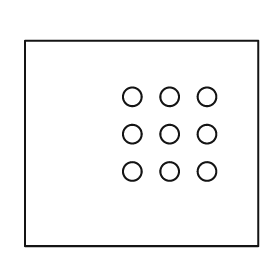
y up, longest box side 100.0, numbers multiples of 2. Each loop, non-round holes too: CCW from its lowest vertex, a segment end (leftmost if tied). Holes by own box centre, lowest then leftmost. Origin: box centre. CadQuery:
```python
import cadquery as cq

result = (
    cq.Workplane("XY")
    .moveTo(-50.0, -44.0)
    .lineTo(50.0, -44.0)
    .lineTo(50.0, 44.0)
    .lineTo(-50.0, 44.0)
    .close()
    .moveTo(-4.0, -12.0)
    .circle(4.0)
    .moveTo(12.0, -12.0)
    .circle(4.0)
    .moveTo(28.0, -12.0)
    .circle(4.0)
    .moveTo(-4.0, 4.0)
    .circle(4.0)
    .moveTo(12.0, 4.0)
    .circle(4.0)
    .moveTo(28.0, 4.0)
    .circle(4.0)
    .moveTo(-4.0, 20.0)
    .circle(4.0)
    .moveTo(12.0, 20.0)
    .circle(4.0)
    .moveTo(28.0, 20.0)
    .circle(4.0)
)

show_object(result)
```